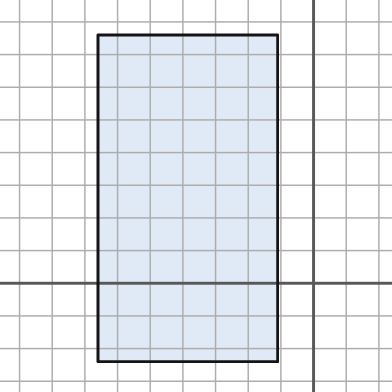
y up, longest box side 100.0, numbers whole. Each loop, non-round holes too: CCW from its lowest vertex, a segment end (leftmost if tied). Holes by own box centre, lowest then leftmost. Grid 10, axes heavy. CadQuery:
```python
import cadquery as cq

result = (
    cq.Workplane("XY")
    .moveTo(-66.0, -24.0)
    .lineTo(-11.0, -24.0)
    .lineTo(-11.0, 76.0)
    .lineTo(-66.0, 76.0)
    .close()
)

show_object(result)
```